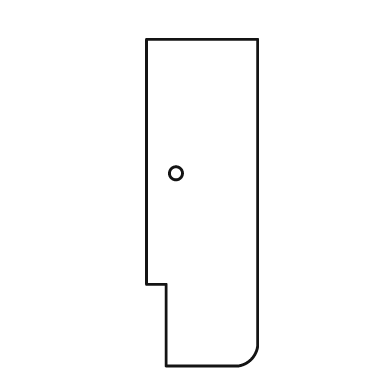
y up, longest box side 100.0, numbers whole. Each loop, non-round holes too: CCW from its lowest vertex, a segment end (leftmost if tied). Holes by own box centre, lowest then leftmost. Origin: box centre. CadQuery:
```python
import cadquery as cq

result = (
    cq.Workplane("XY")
    .moveTo(-11.0, -50.0)
    .lineTo(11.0, -50.0)
    .threePointArc((15.0, -48.0), (17.0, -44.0))
    .lineTo(17.0, 50.0)
    .lineTo(-17.0, 50.0)
    .lineTo(-17.0, -25.0)
    .lineTo(-11.0, -25.0)
    .close()
    .moveTo(-8.0, 9.0)
    .circle(2.0)
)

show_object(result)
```